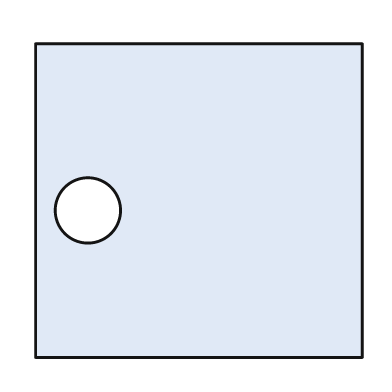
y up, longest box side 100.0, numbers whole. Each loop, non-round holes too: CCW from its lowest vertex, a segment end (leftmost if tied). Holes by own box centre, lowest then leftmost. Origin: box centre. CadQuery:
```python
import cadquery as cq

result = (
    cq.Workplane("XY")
    .moveTo(-50.0, -48.0)
    .lineTo(50.0, -48.0)
    .lineTo(50.0, 48.0)
    .lineTo(-50.0, 48.0)
    .close()
    .moveTo(-34.0, -3.0)
    .circle(10.0)
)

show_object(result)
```